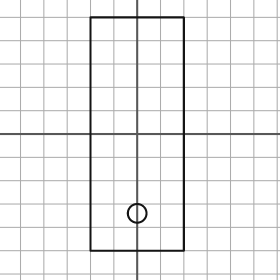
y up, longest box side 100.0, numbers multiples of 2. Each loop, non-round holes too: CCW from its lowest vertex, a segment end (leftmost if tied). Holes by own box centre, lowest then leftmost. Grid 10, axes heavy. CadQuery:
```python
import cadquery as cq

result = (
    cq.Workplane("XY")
    .moveTo(-20.0, -50.0)
    .lineTo(20.0, -50.0)
    .lineTo(20.0, 50.0)
    .lineTo(-20.0, 50.0)
    .close()
    .moveTo(0.0, -34.0)
    .circle(4.0)
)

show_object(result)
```